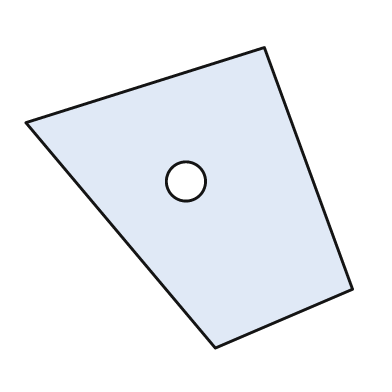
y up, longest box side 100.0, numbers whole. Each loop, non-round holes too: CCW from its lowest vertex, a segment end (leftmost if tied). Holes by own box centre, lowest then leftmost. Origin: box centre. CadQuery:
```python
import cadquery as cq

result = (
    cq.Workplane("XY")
    .moveTo(8.0, -46.0)
    .lineTo(50.0, -28.0)
    .lineTo(23.0, 46.0)
    .lineTo(-50.0, 23.0)
    .close()
    .moveTo(-1.0, 5.0)
    .circle(6.0)
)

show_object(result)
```